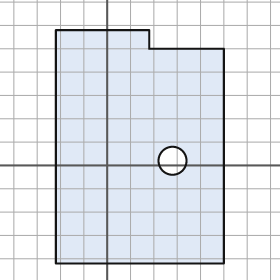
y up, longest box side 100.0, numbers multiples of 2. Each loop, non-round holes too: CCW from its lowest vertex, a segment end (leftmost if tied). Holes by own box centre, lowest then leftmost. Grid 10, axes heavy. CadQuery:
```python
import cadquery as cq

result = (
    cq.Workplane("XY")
    .moveTo(-22.0, -42.0)
    .lineTo(50.0, -42.0)
    .lineTo(50.0, 50.0)
    .lineTo(18.0, 50.0)
    .lineTo(18.0, 58.0)
    .lineTo(-22.0, 58.0)
    .close()
    .moveTo(28.0, 2.0)
    .circle(6.0)
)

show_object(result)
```